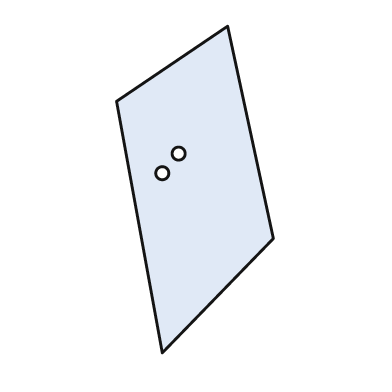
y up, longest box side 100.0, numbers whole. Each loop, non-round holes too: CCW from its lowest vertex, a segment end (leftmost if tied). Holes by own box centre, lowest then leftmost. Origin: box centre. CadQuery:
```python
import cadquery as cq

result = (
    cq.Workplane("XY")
    .moveTo(-10.0, -50.0)
    .lineTo(24.0, -15.0)
    .lineTo(10.0, 50.0)
    .lineTo(-24.0, 27.0)
    .close()
    .moveTo(-10.0, 5.0)
    .circle(2.0)
    .moveTo(-5.0, 11.0)
    .circle(2.0)
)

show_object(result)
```